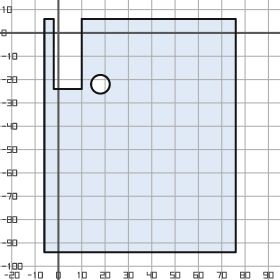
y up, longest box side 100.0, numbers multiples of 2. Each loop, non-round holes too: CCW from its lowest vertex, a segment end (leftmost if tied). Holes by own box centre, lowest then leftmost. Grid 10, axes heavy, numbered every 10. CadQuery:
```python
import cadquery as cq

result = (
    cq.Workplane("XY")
    .moveTo(-6.0, -94.0)
    .lineTo(76.0, -94.0)
    .lineTo(76.0, 6.0)
    .lineTo(10.0, 6.0)
    .lineTo(10.0, -24.0)
    .lineTo(-2.0, -24.0)
    .lineTo(-2.0, 6.0)
    .lineTo(-6.0, 6.0)
    .close()
    .moveTo(18.0, -22.0)
    .circle(4.0)
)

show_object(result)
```